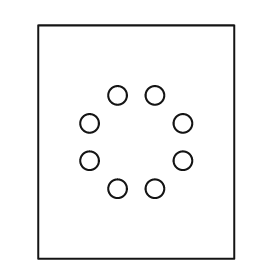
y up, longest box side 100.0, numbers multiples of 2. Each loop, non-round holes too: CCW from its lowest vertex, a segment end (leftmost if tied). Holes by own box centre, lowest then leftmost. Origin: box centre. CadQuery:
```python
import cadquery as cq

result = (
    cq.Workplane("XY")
    .moveTo(-42.0, -50.0)
    .lineTo(42.0, -50.0)
    .lineTo(42.0, 50.0)
    .lineTo(-42.0, 50.0)
    .close()
    .moveTo(-8.0, -20.0)
    .circle(4.0)
    .moveTo(8.0, -20.0)
    .circle(4.0)
    .moveTo(-20.0, -8.0)
    .circle(4.0)
    .moveTo(20.0, -8.0)
    .circle(4.0)
    .moveTo(-20.0, 8.0)
    .circle(4.0)
    .moveTo(20.0, 8.0)
    .circle(4.0)
    .moveTo(-8.0, 20.0)
    .circle(4.0)
    .moveTo(8.0, 20.0)
    .circle(4.0)
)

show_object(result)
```